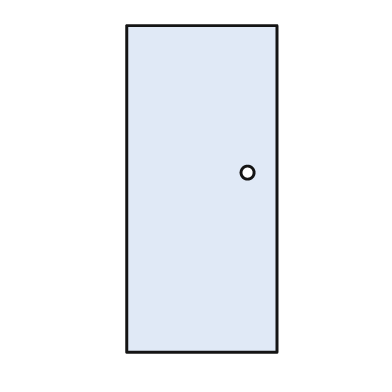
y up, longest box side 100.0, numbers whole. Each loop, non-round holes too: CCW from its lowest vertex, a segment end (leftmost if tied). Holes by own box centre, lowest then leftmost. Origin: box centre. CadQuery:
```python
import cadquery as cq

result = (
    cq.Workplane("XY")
    .moveTo(-23.0, -50.0)
    .lineTo(23.0, -50.0)
    .lineTo(23.0, 50.0)
    .lineTo(-23.0, 50.0)
    .close()
    .moveTo(14.0, 5.0)
    .circle(2.0)
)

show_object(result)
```